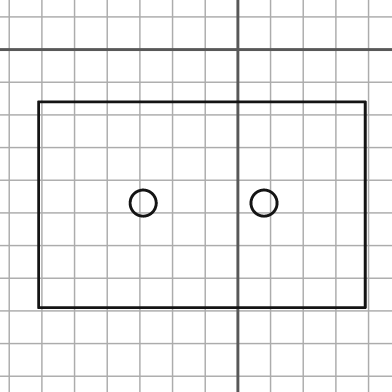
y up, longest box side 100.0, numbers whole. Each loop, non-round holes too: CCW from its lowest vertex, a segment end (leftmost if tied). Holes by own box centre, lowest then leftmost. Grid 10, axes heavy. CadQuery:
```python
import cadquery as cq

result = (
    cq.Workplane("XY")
    .moveTo(-61.0, -79.0)
    .lineTo(39.0, -79.0)
    .lineTo(39.0, -16.0)
    .lineTo(-61.0, -16.0)
    .close()
    .moveTo(-29.0, -47.0)
    .circle(4.0)
    .moveTo(8.0, -47.0)
    .circle(4.0)
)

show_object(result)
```